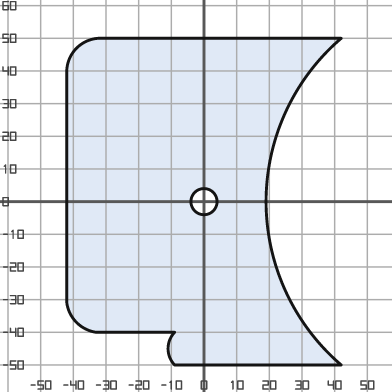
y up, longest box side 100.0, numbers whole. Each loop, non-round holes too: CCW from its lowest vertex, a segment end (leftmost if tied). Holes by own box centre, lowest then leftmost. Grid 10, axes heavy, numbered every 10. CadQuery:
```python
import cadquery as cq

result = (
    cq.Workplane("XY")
    .moveTo(-9.0, -50.0)
    .lineTo(42.0, -50.0)
    .threePointArc((19.0, 0.0), (42.0, 50.0))
    .lineTo(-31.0, 50.0)
    .threePointArc((-39.0, 47.0), (-42.0, 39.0))
    .lineTo(-42.0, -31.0)
    .threePointArc((-39.0, -37.0), (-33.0, -40.0))
    .lineTo(-9.0, -40.0)
    .threePointArc((-11.0, -45.0), (-9.0, -50.0))
    .close()
    .moveTo(0.0, 0.0)
    .circle(4.0)
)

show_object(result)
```